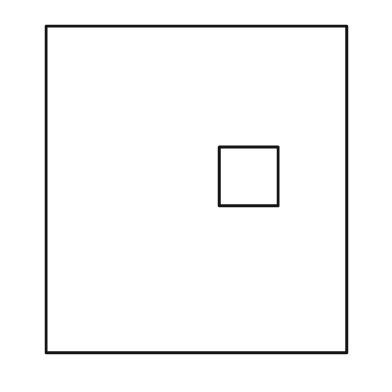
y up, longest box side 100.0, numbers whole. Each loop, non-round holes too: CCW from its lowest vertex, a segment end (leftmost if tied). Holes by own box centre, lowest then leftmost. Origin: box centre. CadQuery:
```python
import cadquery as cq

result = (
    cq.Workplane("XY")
    .moveTo(-46.0, -50.0)
    .lineTo(46.0, -50.0)
    .lineTo(46.0, 50.0)
    .lineTo(-46.0, 50.0)
    .close()
    .moveTo(7.0, -5.0)
    .lineTo(25.0, -5.0)
    .lineTo(25.0, 13.0)
    .lineTo(7.0, 13.0)
    .close()
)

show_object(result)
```